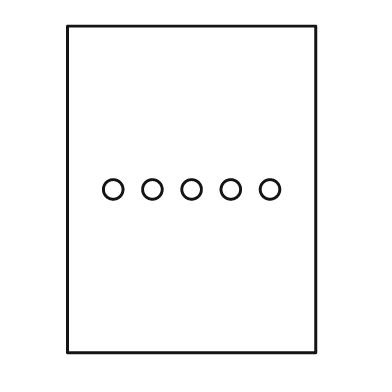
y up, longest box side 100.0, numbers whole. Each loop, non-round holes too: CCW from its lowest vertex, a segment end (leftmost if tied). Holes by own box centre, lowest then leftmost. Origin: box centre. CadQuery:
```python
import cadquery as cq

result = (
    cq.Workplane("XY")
    .moveTo(-38.0, -50.0)
    .lineTo(38.0, -50.0)
    .lineTo(38.0, 50.0)
    .lineTo(-38.0, 50.0)
    .close()
    .moveTo(-24.0, 0.0)
    .circle(3.0)
    .moveTo(-12.0, 0.0)
    .circle(3.0)
    .moveTo(0.0, 0.0)
    .circle(3.0)
    .moveTo(12.0, 0.0)
    .circle(3.0)
    .moveTo(24.0, 0.0)
    .circle(3.0)
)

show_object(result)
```